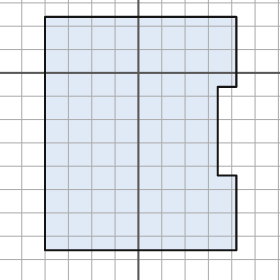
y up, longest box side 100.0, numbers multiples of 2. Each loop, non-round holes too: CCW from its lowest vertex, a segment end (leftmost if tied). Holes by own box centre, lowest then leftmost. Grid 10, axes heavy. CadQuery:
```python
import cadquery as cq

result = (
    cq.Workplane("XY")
    .moveTo(-40.0, -76.0)
    .lineTo(42.0, -76.0)
    .lineTo(42.0, -44.0)
    .lineTo(34.0, -44.0)
    .lineTo(34.0, -6.0)
    .lineTo(42.0, -6.0)
    .lineTo(42.0, 24.0)
    .lineTo(-40.0, 24.0)
    .close()
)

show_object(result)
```